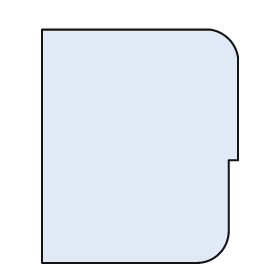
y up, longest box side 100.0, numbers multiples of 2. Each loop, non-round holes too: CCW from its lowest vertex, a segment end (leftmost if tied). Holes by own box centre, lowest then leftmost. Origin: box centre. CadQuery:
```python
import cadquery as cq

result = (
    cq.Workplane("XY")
    .moveTo(-42.0, -50.0)
    .lineTo(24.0, -50.0)
    .threePointArc((34.0, -46.0), (38.0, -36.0))
    .lineTo(38.0, -6.0)
    .lineTo(42.0, -6.0)
    .lineTo(42.0, 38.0)
    .threePointArc((38.0, 46.0), (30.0, 50.0))
    .lineTo(-42.0, 50.0)
    .close()
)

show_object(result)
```